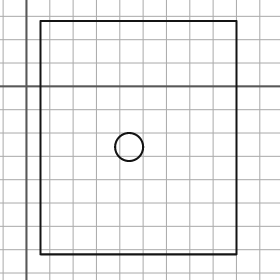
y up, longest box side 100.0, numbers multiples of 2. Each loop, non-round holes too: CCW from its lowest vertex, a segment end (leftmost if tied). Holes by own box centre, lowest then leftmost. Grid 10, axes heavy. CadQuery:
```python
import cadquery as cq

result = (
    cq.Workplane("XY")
    .moveTo(6.0, -72.0)
    .lineTo(90.0, -72.0)
    .lineTo(90.0, 28.0)
    .lineTo(6.0, 28.0)
    .close()
    .moveTo(44.0, -26.0)
    .circle(6.0)
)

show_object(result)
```